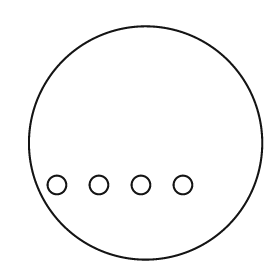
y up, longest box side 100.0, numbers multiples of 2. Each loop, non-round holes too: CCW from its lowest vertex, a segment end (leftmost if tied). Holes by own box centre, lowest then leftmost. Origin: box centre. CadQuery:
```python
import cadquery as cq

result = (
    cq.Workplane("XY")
    .moveTo(0.0, 0.0)
    .circle(50.0)
    .moveTo(-38.0, -18.0)
    .circle(4.0)
    .moveTo(-20.0, -18.0)
    .circle(4.0)
    .moveTo(-2.0, -18.0)
    .circle(4.0)
    .moveTo(16.0, -18.0)
    .circle(4.0)
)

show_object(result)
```